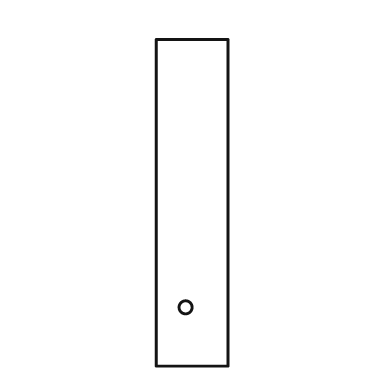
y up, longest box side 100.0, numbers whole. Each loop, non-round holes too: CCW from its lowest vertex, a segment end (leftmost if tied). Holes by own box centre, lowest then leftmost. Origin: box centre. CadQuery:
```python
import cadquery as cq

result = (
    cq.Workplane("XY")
    .moveTo(-11.0, -50.0)
    .lineTo(11.0, -50.0)
    .lineTo(11.0, 50.0)
    .lineTo(-11.0, 50.0)
    .close()
    .moveTo(-2.0, -32.0)
    .circle(2.0)
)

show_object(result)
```